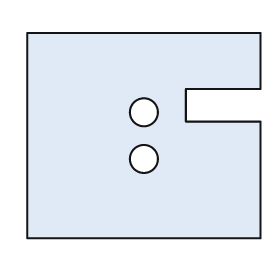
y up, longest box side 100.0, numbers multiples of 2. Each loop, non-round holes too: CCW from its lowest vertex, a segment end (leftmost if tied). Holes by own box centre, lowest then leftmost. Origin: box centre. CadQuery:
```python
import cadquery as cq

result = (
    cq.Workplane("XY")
    .moveTo(-50.0, -44.0)
    .lineTo(50.0, -44.0)
    .lineTo(50.0, 6.0)
    .lineTo(18.0, 6.0)
    .lineTo(18.0, 20.0)
    .lineTo(50.0, 20.0)
    .lineTo(50.0, 44.0)
    .lineTo(-50.0, 44.0)
    .close()
    .moveTo(0.0, -10.0)
    .circle(6.0)
    .moveTo(0.0, 10.0)
    .circle(6.0)
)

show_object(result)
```